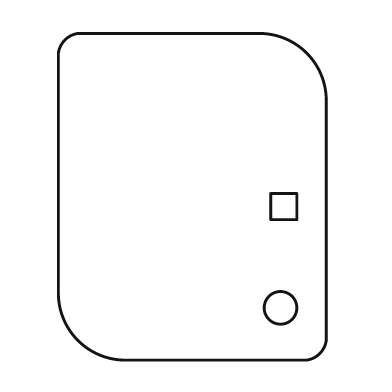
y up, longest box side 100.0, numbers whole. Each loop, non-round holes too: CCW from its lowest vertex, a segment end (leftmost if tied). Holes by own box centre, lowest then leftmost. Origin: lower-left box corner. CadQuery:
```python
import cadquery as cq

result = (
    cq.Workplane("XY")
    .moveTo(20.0, 0.0)
    .lineTo(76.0, 0.0)
    .threePointArc((80.0, 2.0), (82.0, 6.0))
    .lineTo(82.0, 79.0)
    .threePointArc((76.0, 94.0), (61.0, 100.0))
    .lineTo(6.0, 100.0)
    .threePointArc((2.0, 98.0), (0.0, 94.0))
    .lineTo(0.0, 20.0)
    .threePointArc((6.0, 6.0), (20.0, 0.0))
    .close()
    .moveTo(68.0, 16.0)
    .circle(5.0)
    .moveTo(65.0, 43.0)
    .lineTo(73.0, 43.0)
    .lineTo(73.0, 51.0)
    .lineTo(65.0, 51.0)
    .close()
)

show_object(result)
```